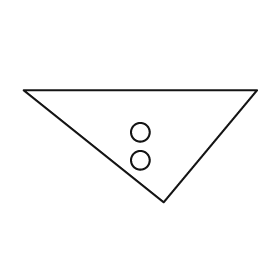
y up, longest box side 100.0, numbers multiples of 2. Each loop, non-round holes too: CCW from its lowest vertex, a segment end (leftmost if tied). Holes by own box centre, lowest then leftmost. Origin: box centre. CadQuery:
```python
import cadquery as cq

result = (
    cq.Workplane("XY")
    .moveTo(10.0, -24.0)
    .lineTo(50.0, 24.0)
    .lineTo(-50.0, 24.0)
    .close()
    .moveTo(0.0, -6.0)
    .circle(4.0)
    .moveTo(0.0, 6.0)
    .circle(4.0)
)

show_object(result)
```